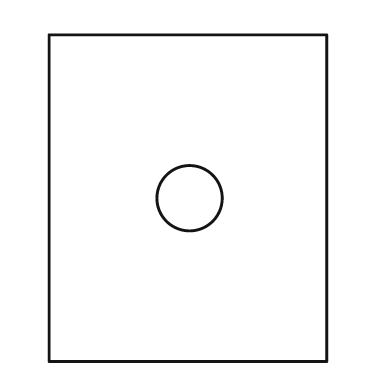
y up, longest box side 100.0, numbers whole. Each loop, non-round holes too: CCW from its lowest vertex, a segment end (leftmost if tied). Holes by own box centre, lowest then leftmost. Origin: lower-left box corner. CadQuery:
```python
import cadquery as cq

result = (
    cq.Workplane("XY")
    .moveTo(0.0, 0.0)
    .lineTo(85.0, 0.0)
    .lineTo(85.0, 100.0)
    .lineTo(0.0, 100.0)
    .close()
    .moveTo(43.0, 50.0)
    .circle(10.0)
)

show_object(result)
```